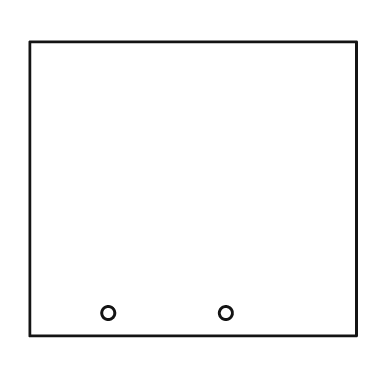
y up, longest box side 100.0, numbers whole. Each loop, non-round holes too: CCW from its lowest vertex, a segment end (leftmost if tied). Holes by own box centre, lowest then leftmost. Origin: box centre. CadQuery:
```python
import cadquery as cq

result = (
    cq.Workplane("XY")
    .moveTo(-50.0, -45.0)
    .lineTo(50.0, -45.0)
    .lineTo(50.0, 45.0)
    .lineTo(-50.0, 45.0)
    .close()
    .moveTo(-26.0, -38.0)
    .circle(2.0)
    .moveTo(10.0, -38.0)
    .circle(2.0)
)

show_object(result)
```